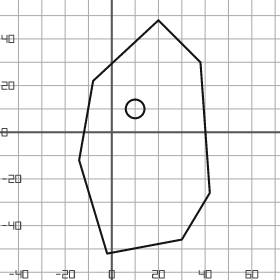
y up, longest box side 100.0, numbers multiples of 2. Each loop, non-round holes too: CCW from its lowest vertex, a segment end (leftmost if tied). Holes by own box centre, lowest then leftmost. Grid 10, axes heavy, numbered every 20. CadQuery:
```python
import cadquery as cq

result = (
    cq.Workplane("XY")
    .moveTo(-2.0, -52.0)
    .lineTo(30.0, -46.0)
    .lineTo(42.0, -26.0)
    .lineTo(38.0, 30.0)
    .lineTo(20.0, 48.0)
    .lineTo(-8.0, 22.0)
    .lineTo(-14.0, -12.0)
    .close()
    .moveTo(10.0, 10.0)
    .circle(4.0)
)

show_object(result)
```